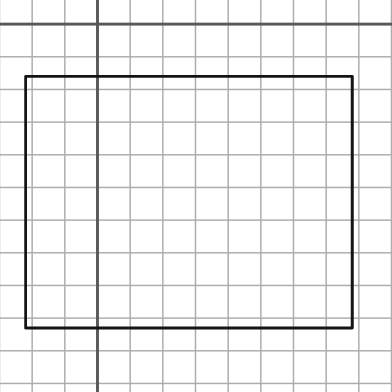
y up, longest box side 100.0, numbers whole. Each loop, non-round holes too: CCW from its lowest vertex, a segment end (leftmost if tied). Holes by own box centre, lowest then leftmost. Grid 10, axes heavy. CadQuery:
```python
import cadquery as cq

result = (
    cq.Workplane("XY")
    .moveTo(-22.0, -93.0)
    .lineTo(78.0, -93.0)
    .lineTo(78.0, -16.0)
    .lineTo(-22.0, -16.0)
    .close()
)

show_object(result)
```